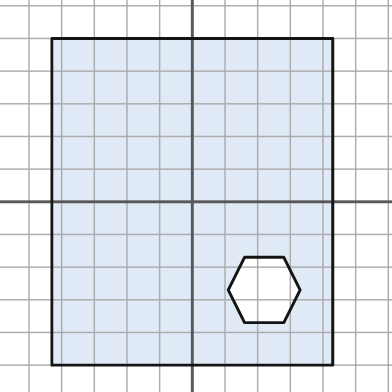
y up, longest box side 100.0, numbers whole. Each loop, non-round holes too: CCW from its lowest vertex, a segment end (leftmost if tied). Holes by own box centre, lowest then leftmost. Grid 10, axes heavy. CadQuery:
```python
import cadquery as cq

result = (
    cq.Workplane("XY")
    .moveTo(-43.0, -50.0)
    .lineTo(43.0, -50.0)
    .lineTo(43.0, 50.0)
    .lineTo(-43.0, 50.0)
    .close()
    .moveTo(16.0, -37.0)
    .lineTo(28.0, -37.0)
    .lineTo(33.0, -27.0)
    .lineTo(28.0, -17.0)
    .lineTo(16.0, -17.0)
    .lineTo(11.0, -27.0)
    .close()
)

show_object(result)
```